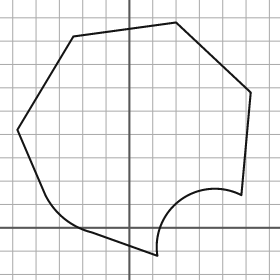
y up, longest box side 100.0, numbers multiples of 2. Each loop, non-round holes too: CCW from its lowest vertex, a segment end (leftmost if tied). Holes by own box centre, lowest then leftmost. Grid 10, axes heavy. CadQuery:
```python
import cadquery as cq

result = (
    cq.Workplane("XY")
    .moveTo(12.0, -12.0)
    .threePointArc((22.0, 12.0), (48.0, 14.0))
    .lineTo(52.0, 58.0)
    .lineTo(20.0, 88.0)
    .lineTo(-24.0, 82.0)
    .lineTo(-48.0, 42.0)
    .lineTo(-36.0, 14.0)
    .threePointArc((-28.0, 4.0), (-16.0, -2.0))
    .close()
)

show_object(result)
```